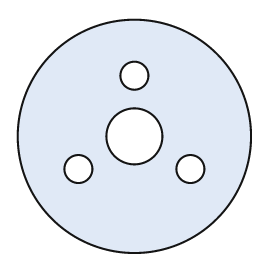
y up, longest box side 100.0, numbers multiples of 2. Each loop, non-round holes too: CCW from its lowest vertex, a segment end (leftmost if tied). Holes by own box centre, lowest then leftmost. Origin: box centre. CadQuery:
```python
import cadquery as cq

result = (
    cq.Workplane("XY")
    .moveTo(0.0, 0.0)
    .circle(50.0)
    .moveTo(-24.0, -14.0)
    .circle(6.0)
    .moveTo(24.0, -14.0)
    .circle(6.0)
    .moveTo(0.0, 0.0)
    .circle(12.0)
    .moveTo(0.0, 26.0)
    .circle(6.0)
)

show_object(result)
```